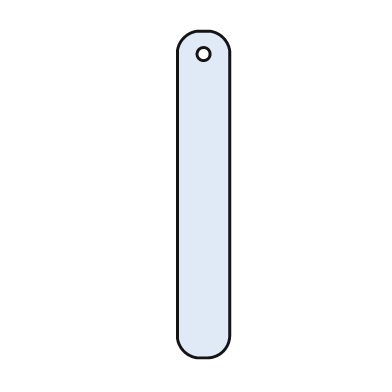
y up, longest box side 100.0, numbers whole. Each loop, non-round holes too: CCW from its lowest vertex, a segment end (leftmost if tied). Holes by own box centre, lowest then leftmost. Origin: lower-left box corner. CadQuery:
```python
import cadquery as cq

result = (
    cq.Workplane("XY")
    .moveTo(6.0, 0.0)
    .lineTo(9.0, 0.0)
    .threePointArc((14.0, 2.0), (16.0, 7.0))
    .lineTo(16.0, 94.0)
    .threePointArc((14.0, 98.0), (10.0, 100.0))
    .lineTo(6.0, 100.0)
    .threePointArc((2.0, 98.0), (0.0, 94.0))
    .lineTo(0.0, 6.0)
    .threePointArc((2.0, 2.0), (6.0, 0.0))
    .close()
    .moveTo(8.0, 93.0)
    .circle(2.0)
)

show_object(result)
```